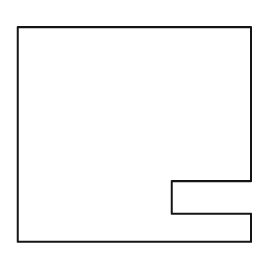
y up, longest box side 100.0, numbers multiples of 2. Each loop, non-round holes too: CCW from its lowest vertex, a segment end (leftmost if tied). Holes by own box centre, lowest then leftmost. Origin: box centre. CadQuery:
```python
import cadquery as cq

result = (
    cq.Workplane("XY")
    .moveTo(-50.0, -46.0)
    .lineTo(50.0, -46.0)
    .lineTo(50.0, -34.0)
    .lineTo(16.0, -34.0)
    .lineTo(16.0, -20.0)
    .lineTo(50.0, -20.0)
    .lineTo(50.0, 46.0)
    .lineTo(-50.0, 46.0)
    .close()
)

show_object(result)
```